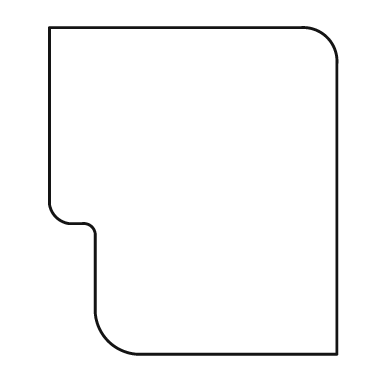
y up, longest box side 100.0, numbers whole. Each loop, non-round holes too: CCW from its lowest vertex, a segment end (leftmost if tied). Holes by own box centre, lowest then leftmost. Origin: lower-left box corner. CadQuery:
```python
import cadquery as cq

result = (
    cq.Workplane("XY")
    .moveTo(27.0, 0.0)
    .lineTo(88.0, 0.0)
    .lineTo(88.0, 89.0)
    .threePointArc((85.0, 97.0), (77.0, 100.0))
    .lineTo(0.0, 100.0)
    .lineTo(0.0, 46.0)
    .threePointArc((2.0, 42.0), (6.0, 40.0))
    .lineTo(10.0, 40.0)
    .threePointArc((13.0, 39.0), (14.0, 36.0))
    .lineTo(14.0, 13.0)
    .threePointArc((18.0, 4.0), (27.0, 0.0))
    .close()
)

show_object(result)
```